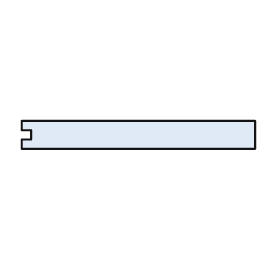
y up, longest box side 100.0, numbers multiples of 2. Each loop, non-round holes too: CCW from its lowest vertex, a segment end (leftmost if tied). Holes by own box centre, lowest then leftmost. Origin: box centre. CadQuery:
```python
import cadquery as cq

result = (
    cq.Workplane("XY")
    .moveTo(-50.0, -6.0)
    .lineTo(50.0, -6.0)
    .lineTo(50.0, 6.0)
    .lineTo(-50.0, 6.0)
    .lineTo(-50.0, 2.0)
    .lineTo(-46.0, 2.0)
    .lineTo(-46.0, -2.0)
    .lineTo(-50.0, -2.0)
    .close()
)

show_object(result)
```